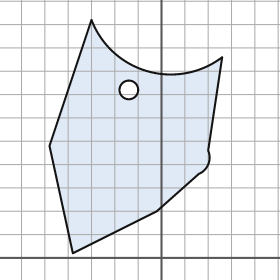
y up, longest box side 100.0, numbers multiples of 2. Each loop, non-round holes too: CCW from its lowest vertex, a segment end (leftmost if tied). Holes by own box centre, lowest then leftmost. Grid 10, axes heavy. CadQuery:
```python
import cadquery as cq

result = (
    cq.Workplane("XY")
    .moveTo(-38.0, 2.0)
    .lineTo(-2.0, 20.0)
    .lineTo(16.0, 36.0)
    .threePointArc((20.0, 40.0), (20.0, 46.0))
    .lineTo(26.0, 86.0)
    .threePointArc((-6.0, 80.0), (-30.0, 102.0))
    .lineTo(-48.0, 48.0)
    .close()
    .moveTo(-14.0, 72.0)
    .circle(4.0)
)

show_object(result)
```